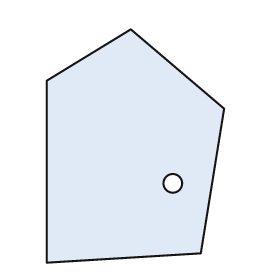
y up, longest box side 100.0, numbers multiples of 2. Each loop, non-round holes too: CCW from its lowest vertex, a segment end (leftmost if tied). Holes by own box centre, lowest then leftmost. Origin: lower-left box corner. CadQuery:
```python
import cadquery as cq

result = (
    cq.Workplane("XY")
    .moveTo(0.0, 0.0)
    .lineTo(66.0, 4.0)
    .lineTo(76.0, 66.0)
    .lineTo(36.0, 100.0)
    .lineTo(0.0, 78.0)
    .close()
    .moveTo(54.0, 34.0)
    .circle(4.0)
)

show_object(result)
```